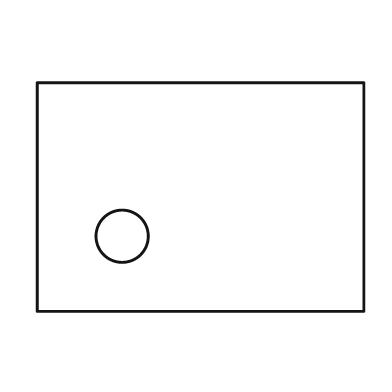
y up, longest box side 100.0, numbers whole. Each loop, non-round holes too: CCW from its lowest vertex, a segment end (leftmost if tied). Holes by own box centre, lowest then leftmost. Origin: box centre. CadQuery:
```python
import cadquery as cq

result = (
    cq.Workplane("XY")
    .moveTo(-50.0, -35.0)
    .lineTo(50.0, -35.0)
    .lineTo(50.0, 35.0)
    .lineTo(-50.0, 35.0)
    .close()
    .moveTo(-24.0, -12.0)
    .circle(8.0)
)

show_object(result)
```